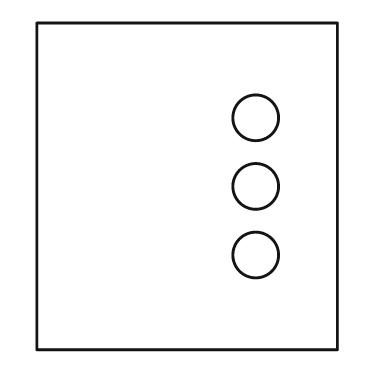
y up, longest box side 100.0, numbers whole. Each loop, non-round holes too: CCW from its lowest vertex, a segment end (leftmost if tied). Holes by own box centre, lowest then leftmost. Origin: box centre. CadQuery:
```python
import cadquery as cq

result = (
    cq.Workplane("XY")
    .moveTo(-46.0, -50.0)
    .lineTo(46.0, -50.0)
    .lineTo(46.0, 50.0)
    .lineTo(-46.0, 50.0)
    .close()
    .moveTo(21.0, -21.0)
    .circle(7.0)
    .moveTo(21.0, 0.0)
    .circle(7.0)
    .moveTo(21.0, 21.0)
    .circle(7.0)
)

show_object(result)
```